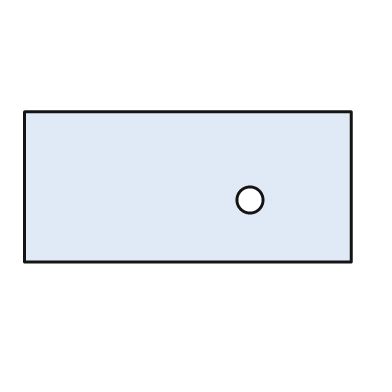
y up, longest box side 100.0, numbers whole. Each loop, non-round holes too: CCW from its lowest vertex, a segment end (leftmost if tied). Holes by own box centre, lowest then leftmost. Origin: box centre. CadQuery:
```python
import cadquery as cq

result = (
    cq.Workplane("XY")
    .moveTo(-50.0, -23.0)
    .lineTo(50.0, -23.0)
    .lineTo(50.0, 23.0)
    .lineTo(-50.0, 23.0)
    .close()
    .moveTo(19.0, -4.0)
    .circle(4.0)
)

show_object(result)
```